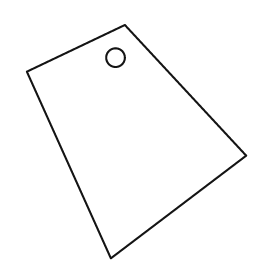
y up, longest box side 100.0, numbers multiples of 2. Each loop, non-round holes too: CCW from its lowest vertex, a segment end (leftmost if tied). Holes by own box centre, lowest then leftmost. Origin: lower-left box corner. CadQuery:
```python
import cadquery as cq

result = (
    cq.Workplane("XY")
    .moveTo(36.0, 0.0)
    .lineTo(94.0, 44.0)
    .lineTo(42.0, 100.0)
    .lineTo(0.0, 80.0)
    .close()
    .moveTo(38.0, 86.0)
    .circle(4.0)
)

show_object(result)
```